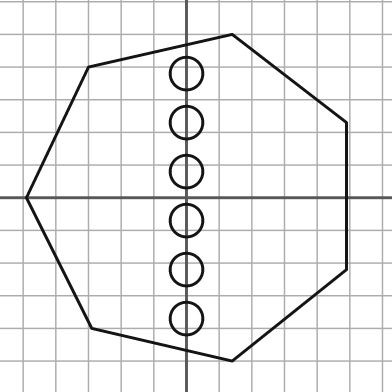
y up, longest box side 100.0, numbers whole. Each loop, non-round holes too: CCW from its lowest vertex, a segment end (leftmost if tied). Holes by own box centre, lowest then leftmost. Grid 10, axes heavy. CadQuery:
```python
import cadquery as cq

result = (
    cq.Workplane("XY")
    .moveTo(14.0, -50.0)
    .lineTo(49.0, -22.0)
    .lineTo(49.0, 23.0)
    .lineTo(14.0, 50.0)
    .lineTo(-30.0, 40.0)
    .lineTo(-49.0, 0.0)
    .lineTo(-29.0, -40.0)
    .close()
    .moveTo(0.0, -37.0)
    .circle(5.0)
    .moveTo(0.0, -22.0)
    .circle(5.0)
    .moveTo(0.0, -7.0)
    .circle(5.0)
    .moveTo(0.0, 8.0)
    .circle(5.0)
    .moveTo(0.0, 23.0)
    .circle(5.0)
    .moveTo(0.0, 38.0)
    .circle(5.0)
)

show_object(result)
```